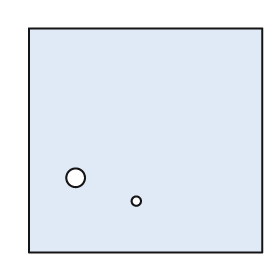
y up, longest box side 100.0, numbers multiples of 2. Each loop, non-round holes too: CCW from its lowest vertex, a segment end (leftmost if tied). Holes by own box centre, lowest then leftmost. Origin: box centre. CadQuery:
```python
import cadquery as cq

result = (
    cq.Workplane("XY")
    .moveTo(-50.0, -48.0)
    .lineTo(50.0, -48.0)
    .lineTo(50.0, 48.0)
    .lineTo(-50.0, 48.0)
    .close()
    .moveTo(-4.0, -26.0)
    .circle(2.0)
    .moveTo(-30.0, -16.0)
    .circle(4.0)
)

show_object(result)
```